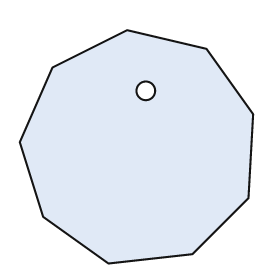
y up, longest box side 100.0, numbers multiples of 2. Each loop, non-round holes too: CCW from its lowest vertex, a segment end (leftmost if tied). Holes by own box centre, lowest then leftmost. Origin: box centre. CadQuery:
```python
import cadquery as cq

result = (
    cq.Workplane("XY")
    .moveTo(-12.0, -50.0)
    .lineTo(24.0, -46.0)
    .lineTo(48.0, -22.0)
    .lineTo(50.0, 14.0)
    .lineTo(30.0, 42.0)
    .lineTo(-4.0, 50.0)
    .lineTo(-36.0, 34.0)
    .lineTo(-50.0, 2.0)
    .lineTo(-40.0, -30.0)
    .close()
    .moveTo(4.0, 24.0)
    .circle(4.0)
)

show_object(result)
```